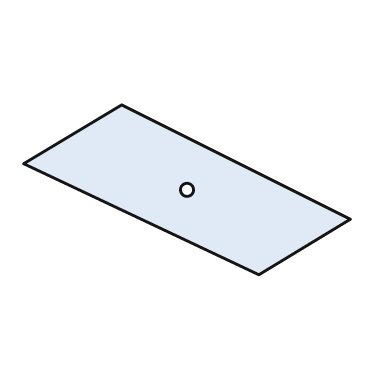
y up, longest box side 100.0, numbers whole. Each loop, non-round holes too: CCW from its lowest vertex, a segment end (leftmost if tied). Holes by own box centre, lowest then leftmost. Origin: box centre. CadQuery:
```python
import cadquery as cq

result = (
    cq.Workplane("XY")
    .moveTo(22.0, -26.0)
    .lineTo(50.0, -9.0)
    .lineTo(-20.0, 26.0)
    .lineTo(-50.0, 8.0)
    .close()
    .moveTo(0.0, 0.0)
    .circle(2.0)
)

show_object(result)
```